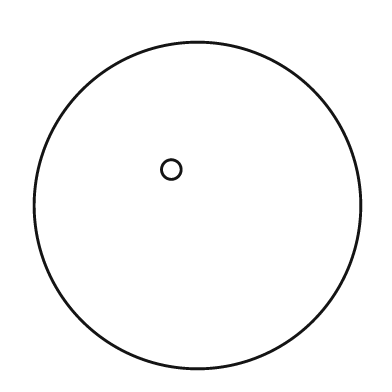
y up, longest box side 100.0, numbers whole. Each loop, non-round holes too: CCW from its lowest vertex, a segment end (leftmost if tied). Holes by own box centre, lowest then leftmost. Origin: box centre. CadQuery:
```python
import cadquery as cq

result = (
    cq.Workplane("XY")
    .moveTo(0.0, 0.0)
    .circle(50.0)
    .moveTo(-8.0, 11.0)
    .circle(3.0)
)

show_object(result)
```